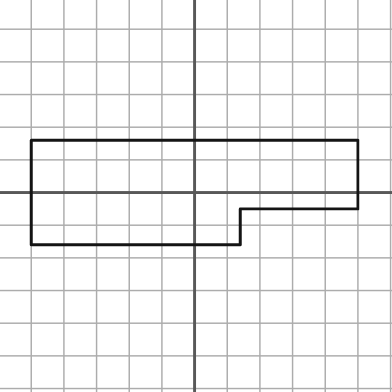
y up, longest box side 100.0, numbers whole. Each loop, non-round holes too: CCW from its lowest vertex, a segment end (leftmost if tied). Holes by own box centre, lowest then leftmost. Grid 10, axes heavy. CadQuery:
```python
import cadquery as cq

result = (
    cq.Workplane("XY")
    .moveTo(-50.0, -16.0)
    .lineTo(14.0, -16.0)
    .lineTo(14.0, -5.0)
    .lineTo(50.0, -5.0)
    .lineTo(50.0, 16.0)
    .lineTo(-50.0, 16.0)
    .close()
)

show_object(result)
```